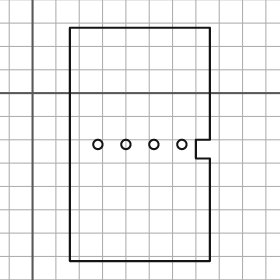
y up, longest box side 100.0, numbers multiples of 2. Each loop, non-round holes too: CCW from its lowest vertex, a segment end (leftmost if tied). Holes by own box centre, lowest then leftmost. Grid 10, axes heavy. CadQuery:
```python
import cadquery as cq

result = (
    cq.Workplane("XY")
    .moveTo(16.0, -72.0)
    .lineTo(76.0, -72.0)
    .lineTo(76.0, -28.0)
    .lineTo(70.0, -28.0)
    .lineTo(70.0, -20.0)
    .lineTo(76.0, -20.0)
    .lineTo(76.0, 28.0)
    .lineTo(16.0, 28.0)
    .close()
    .moveTo(28.0, -22.0)
    .circle(2.0)
    .moveTo(40.0, -22.0)
    .circle(2.0)
    .moveTo(52.0, -22.0)
    .circle(2.0)
    .moveTo(64.0, -22.0)
    .circle(2.0)
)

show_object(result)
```